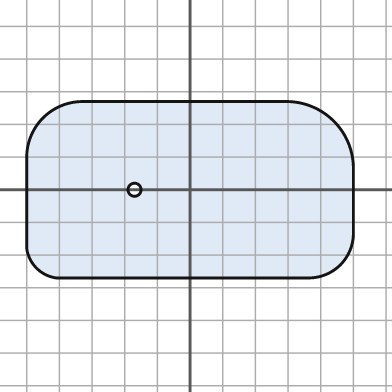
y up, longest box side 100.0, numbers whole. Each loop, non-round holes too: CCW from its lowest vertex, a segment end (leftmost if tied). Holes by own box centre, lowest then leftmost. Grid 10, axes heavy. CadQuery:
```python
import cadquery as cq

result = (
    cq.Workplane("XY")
    .moveTo(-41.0, -27.0)
    .lineTo(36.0, -27.0)
    .threePointArc((46.0, -23.0), (50.0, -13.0))
    .lineTo(50.0, 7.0)
    .threePointArc((44.0, 21.0), (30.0, 27.0))
    .lineTo(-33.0, 27.0)
    .threePointArc((-45.0, 22.0), (-50.0, 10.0))
    .lineTo(-50.0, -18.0)
    .threePointArc((-47.0, -24.0), (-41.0, -27.0))
    .close()
    .moveTo(-17.0, 0.0)
    .circle(2.0)
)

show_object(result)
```